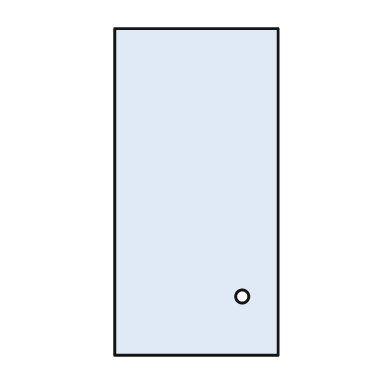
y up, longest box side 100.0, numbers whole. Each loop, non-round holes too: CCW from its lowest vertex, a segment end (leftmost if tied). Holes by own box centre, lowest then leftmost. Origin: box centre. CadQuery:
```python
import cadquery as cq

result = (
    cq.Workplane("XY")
    .moveTo(-25.0, -50.0)
    .lineTo(25.0, -50.0)
    .lineTo(25.0, 50.0)
    .lineTo(-25.0, 50.0)
    .close()
    .moveTo(14.0, -32.0)
    .circle(2.0)
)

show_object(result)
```